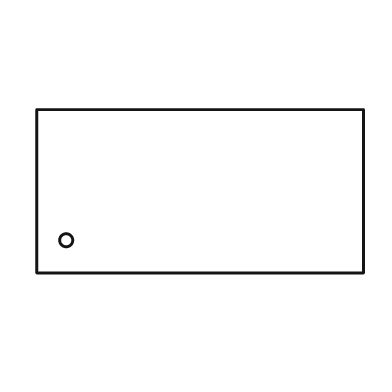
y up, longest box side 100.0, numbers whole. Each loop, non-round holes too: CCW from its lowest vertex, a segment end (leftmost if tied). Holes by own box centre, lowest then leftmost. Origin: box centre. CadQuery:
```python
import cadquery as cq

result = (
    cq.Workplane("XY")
    .moveTo(-50.0, -25.0)
    .lineTo(50.0, -25.0)
    .lineTo(50.0, 25.0)
    .lineTo(-50.0, 25.0)
    .close()
    .moveTo(-41.0, -15.0)
    .circle(2.0)
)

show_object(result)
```